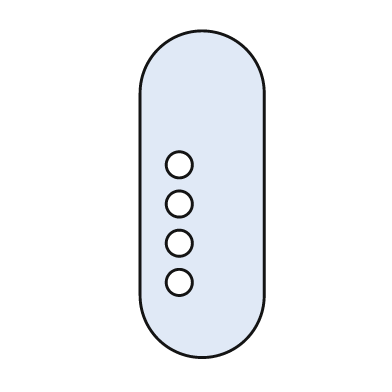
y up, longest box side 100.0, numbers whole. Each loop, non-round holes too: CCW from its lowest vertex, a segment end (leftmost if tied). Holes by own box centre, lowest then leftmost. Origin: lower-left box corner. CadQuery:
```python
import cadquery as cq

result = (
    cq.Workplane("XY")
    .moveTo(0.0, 19.0)
    .threePointArc((19.0, 0.0), (38.0, 19.0))
    .lineTo(38.0, 81.0)
    .threePointArc((19.0, 100.0), (0.0, 81.0))
    .close()
    .moveTo(12.0, 23.0)
    .circle(4.0)
    .moveTo(12.0, 35.0)
    .circle(4.0)
    .moveTo(12.0, 47.0)
    .circle(4.0)
    .moveTo(12.0, 59.0)
    .circle(4.0)
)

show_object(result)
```